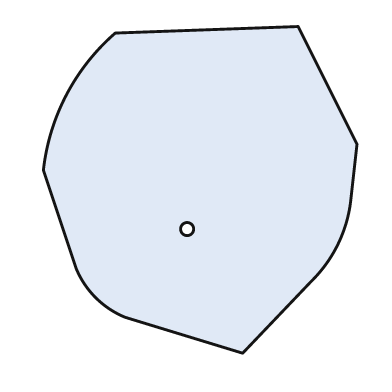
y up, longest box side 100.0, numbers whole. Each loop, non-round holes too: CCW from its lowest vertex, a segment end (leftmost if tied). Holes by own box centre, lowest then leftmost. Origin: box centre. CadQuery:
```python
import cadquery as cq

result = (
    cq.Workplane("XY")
    .moveTo(13.0, -50.0)
    .lineTo(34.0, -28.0)
    .threePointArc((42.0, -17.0), (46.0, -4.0))
    .lineTo(48.0, 14.0)
    .lineTo(30.0, 50.0)
    .lineTo(-26.0, 48.0)
    .threePointArc((-41.0, 29.0), (-48.0, 6.0))
    .lineTo(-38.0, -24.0)
    .threePointArc((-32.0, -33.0), (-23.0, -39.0))
    .close()
    .moveTo(-4.0, -12.0)
    .circle(2.0)
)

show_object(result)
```